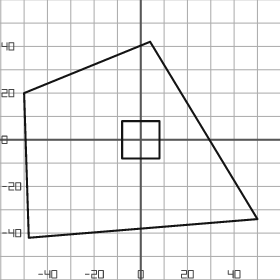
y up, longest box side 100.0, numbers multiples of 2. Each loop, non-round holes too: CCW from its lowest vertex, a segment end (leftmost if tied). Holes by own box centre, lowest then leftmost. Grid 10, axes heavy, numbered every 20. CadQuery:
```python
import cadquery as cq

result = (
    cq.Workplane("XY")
    .moveTo(-48.0, -42.0)
    .lineTo(50.0, -34.0)
    .lineTo(4.0, 42.0)
    .lineTo(-50.0, 20.0)
    .close()
    .moveTo(-8.0, -8.0)
    .lineTo(8.0, -8.0)
    .lineTo(8.0, 8.0)
    .lineTo(-8.0, 8.0)
    .close()
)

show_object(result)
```